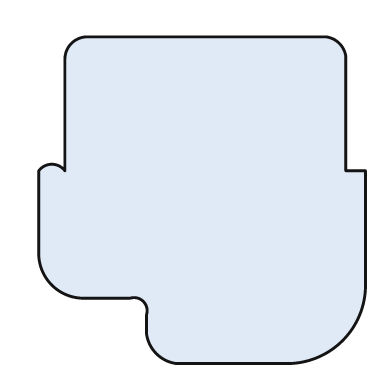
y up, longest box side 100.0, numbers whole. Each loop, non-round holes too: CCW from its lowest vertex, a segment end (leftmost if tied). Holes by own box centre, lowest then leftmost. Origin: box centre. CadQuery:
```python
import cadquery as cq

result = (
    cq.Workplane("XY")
    .moveTo(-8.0, -50.0)
    .lineTo(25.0, -50.0)
    .threePointArc((43.0, -43.0), (50.0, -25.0))
    .lineTo(50.0, 9.0)
    .lineTo(44.0, 9.0)
    .lineTo(44.0, 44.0)
    .threePointArc((42.0, 48.0), (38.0, 50.0))
    .lineTo(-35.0, 50.0)
    .threePointArc((-40.0, 48.0), (-42.0, 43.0))
    .lineTo(-42.0, 9.0)
    .threePointArc((-46.0, 11.0), (-50.0, 9.0))
    .lineTo(-50.0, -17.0)
    .threePointArc((-46.0, -26.0), (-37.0, -30.0))
    .lineTo(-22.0, -30.0)
    .threePointArc((-18.0, -31.0), (-17.0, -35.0))
    .lineTo(-17.0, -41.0)
    .threePointArc((-14.0, -47.0), (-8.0, -50.0))
    .close()
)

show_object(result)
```